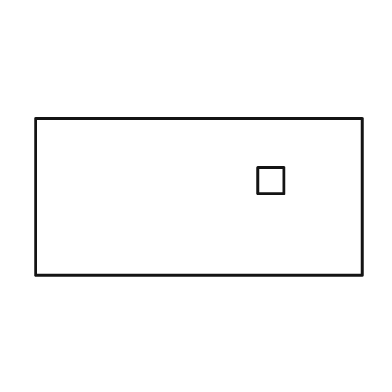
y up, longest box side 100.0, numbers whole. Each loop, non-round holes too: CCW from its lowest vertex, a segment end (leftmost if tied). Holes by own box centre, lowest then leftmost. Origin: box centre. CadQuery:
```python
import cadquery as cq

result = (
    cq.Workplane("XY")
    .moveTo(-50.0, -24.0)
    .lineTo(50.0, -24.0)
    .lineTo(50.0, 24.0)
    .lineTo(-50.0, 24.0)
    .close()
    .moveTo(18.0, 1.0)
    .lineTo(26.0, 1.0)
    .lineTo(26.0, 9.0)
    .lineTo(18.0, 9.0)
    .close()
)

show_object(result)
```